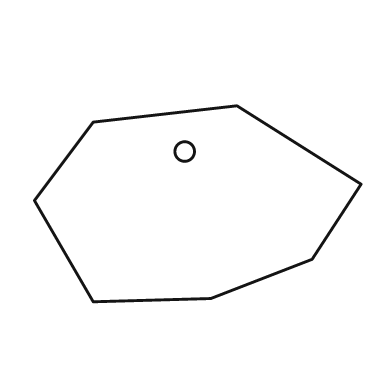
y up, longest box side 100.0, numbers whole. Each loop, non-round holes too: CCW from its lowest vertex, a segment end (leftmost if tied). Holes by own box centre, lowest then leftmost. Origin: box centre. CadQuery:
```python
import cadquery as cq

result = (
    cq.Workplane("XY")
    .moveTo(-32.0, -30.0)
    .lineTo(4.0, -29.0)
    .lineTo(35.0, -17.0)
    .lineTo(50.0, 6.0)
    .lineTo(12.0, 30.0)
    .lineTo(-32.0, 25.0)
    .lineTo(-50.0, 1.0)
    .close()
    .moveTo(-4.0, 16.0)
    .circle(3.0)
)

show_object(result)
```